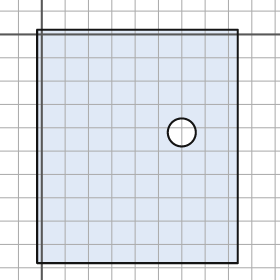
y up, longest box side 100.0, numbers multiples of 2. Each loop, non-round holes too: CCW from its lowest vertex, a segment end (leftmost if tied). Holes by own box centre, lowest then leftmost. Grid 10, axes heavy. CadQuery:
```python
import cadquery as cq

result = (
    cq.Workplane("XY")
    .moveTo(-2.0, -98.0)
    .lineTo(84.0, -98.0)
    .lineTo(84.0, 2.0)
    .lineTo(-2.0, 2.0)
    .close()
    .moveTo(60.0, -42.0)
    .circle(6.0)
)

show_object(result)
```